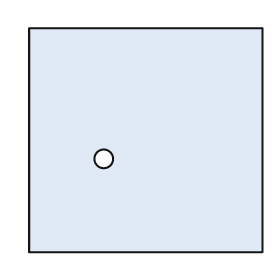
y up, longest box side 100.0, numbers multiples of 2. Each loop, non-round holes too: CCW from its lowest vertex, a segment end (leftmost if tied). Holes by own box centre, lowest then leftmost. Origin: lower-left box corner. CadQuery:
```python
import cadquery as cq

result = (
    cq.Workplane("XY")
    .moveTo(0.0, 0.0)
    .lineTo(100.0, 0.0)
    .lineTo(100.0, 96.0)
    .lineTo(0.0, 96.0)
    .close()
    .moveTo(32.0, 40.0)
    .circle(4.0)
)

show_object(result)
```